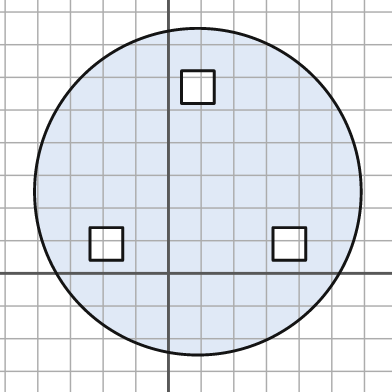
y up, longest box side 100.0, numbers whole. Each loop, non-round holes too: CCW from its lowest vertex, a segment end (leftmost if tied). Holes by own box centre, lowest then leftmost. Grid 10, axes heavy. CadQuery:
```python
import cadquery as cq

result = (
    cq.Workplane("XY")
    .moveTo(9.0, 25.0)
    .circle(50.0)
    .moveTo(-24.0, 4.0)
    .lineTo(-14.0, 4.0)
    .lineTo(-14.0, 14.0)
    .lineTo(-24.0, 14.0)
    .close()
    .moveTo(32.0, 4.0)
    .lineTo(42.0, 4.0)
    .lineTo(42.0, 14.0)
    .lineTo(32.0, 14.0)
    .close()
    .moveTo(4.0, 52.0)
    .lineTo(14.0, 52.0)
    .lineTo(14.0, 62.0)
    .lineTo(4.0, 62.0)
    .close()
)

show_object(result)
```